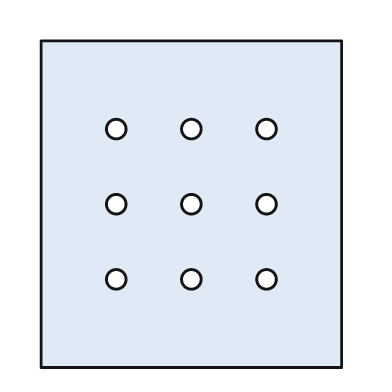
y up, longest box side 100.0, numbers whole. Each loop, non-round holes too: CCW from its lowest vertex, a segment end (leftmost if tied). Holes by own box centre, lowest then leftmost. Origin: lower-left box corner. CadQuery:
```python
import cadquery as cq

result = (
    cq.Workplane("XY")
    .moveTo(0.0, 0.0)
    .lineTo(92.0, 0.0)
    .lineTo(92.0, 100.0)
    .lineTo(0.0, 100.0)
    .close()
    .moveTo(23.0, 27.0)
    .circle(3.0)
    .moveTo(46.0, 27.0)
    .circle(3.0)
    .moveTo(69.0, 27.0)
    .circle(3.0)
    .moveTo(23.0, 50.0)
    .circle(3.0)
    .moveTo(46.0, 50.0)
    .circle(3.0)
    .moveTo(69.0, 50.0)
    .circle(3.0)
    .moveTo(23.0, 73.0)
    .circle(3.0)
    .moveTo(46.0, 73.0)
    .circle(3.0)
    .moveTo(69.0, 73.0)
    .circle(3.0)
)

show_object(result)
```